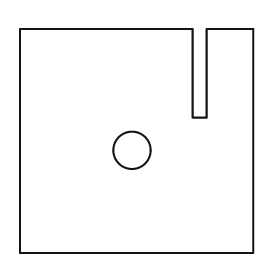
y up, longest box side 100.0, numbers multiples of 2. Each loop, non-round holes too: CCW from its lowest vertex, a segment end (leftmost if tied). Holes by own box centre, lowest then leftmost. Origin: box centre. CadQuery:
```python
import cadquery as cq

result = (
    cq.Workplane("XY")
    .moveTo(-50.0, -48.0)
    .lineTo(50.0, -48.0)
    .lineTo(50.0, 48.0)
    .lineTo(30.0, 48.0)
    .lineTo(30.0, 10.0)
    .lineTo(24.0, 10.0)
    .lineTo(24.0, 48.0)
    .lineTo(-50.0, 48.0)
    .close()
    .moveTo(-2.0, -4.0)
    .circle(8.0)
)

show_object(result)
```